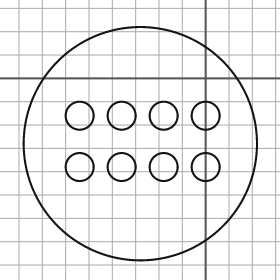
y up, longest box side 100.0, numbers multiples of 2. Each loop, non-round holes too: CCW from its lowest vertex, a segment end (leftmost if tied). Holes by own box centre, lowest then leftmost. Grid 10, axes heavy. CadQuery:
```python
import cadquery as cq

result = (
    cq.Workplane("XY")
    .moveTo(-28.0, -28.0)
    .circle(50.0)
    .moveTo(-54.0, -38.0)
    .circle(6.0)
    .moveTo(-36.0, -38.0)
    .circle(6.0)
    .moveTo(-18.0, -38.0)
    .circle(6.0)
    .moveTo(0.0, -38.0)
    .circle(6.0)
    .moveTo(-54.0, -16.0)
    .circle(6.0)
    .moveTo(-36.0, -16.0)
    .circle(6.0)
    .moveTo(-18.0, -16.0)
    .circle(6.0)
    .moveTo(0.0, -16.0)
    .circle(6.0)
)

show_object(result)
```